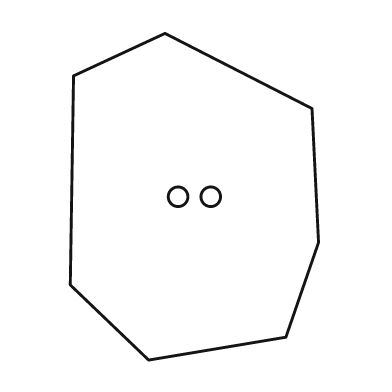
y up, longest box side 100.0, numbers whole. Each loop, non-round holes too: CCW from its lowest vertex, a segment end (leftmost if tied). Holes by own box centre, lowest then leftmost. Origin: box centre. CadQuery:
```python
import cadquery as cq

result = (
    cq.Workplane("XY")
    .moveTo(-14.0, -50.0)
    .lineTo(28.0, -43.0)
    .lineTo(38.0, -14.0)
    .lineTo(36.0, 27.0)
    .lineTo(-9.0, 50.0)
    .lineTo(-37.0, 37.0)
    .lineTo(-38.0, -27.0)
    .close()
    .moveTo(-5.0, 0.0)
    .circle(3.0)
    .moveTo(5.0, 0.0)
    .circle(3.0)
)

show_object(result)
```